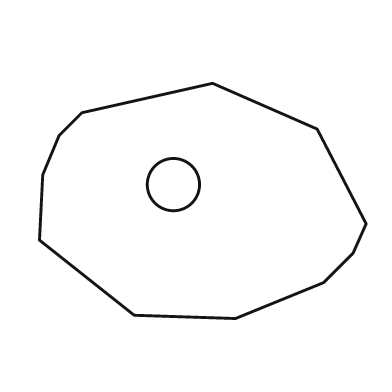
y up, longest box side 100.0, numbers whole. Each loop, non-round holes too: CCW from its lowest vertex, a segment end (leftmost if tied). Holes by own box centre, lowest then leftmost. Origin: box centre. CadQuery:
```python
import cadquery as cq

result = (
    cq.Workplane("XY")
    .moveTo(10.0, -36.0)
    .lineTo(37.0, -25.0)
    .lineTo(46.0, -16.0)
    .lineTo(50.0, -7.0)
    .lineTo(35.0, 22.0)
    .lineTo(3.0, 36.0)
    .lineTo(-37.0, 27.0)
    .lineTo(-44.0, 20.0)
    .lineTo(-49.0, 8.0)
    .lineTo(-50.0, -12.0)
    .lineTo(-21.0, -35.0)
    .close()
    .moveTo(-9.0, 5.0)
    .circle(8.0)
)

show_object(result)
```